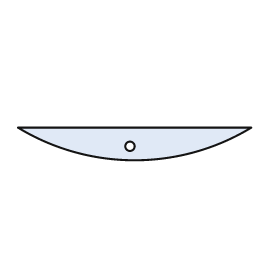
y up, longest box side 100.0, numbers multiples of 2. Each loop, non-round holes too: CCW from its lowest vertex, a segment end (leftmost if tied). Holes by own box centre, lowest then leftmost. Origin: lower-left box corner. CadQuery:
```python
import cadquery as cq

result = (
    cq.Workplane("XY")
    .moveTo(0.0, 14.0)
    .threePointArc((50.0, 0.0), (100.0, 14.0))
    .close()
    .moveTo(48.0, 6.0)
    .circle(2.0)
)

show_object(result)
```